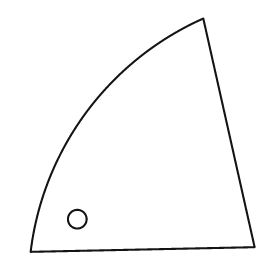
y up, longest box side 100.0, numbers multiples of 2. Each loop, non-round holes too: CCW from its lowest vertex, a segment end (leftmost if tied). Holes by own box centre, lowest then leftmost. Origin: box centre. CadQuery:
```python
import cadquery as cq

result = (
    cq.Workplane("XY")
    .moveTo(-48.0, -50.0)
    .lineTo(48.0, -48.0)
    .lineTo(26.0, 50.0)
    .threePointArc((-24.0, 10.0), (-48.0, -50.0))
    .close()
    .moveTo(-28.0, -36.0)
    .circle(4.0)
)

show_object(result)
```